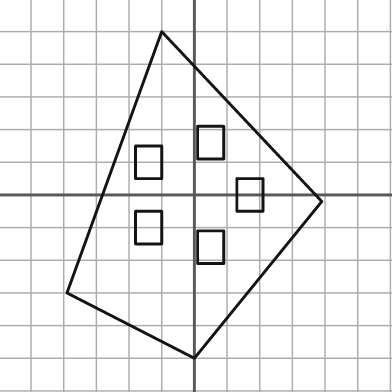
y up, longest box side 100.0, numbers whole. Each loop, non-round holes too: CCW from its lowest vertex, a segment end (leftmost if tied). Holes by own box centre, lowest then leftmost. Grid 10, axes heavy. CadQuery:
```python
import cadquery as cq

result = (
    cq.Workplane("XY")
    .moveTo(0.0, -50.0)
    .lineTo(39.0, -2.0)
    .lineTo(-10.0, 50.0)
    .lineTo(-39.0, -30.0)
    .close()
    .moveTo(1.0, -21.0)
    .lineTo(9.0, -21.0)
    .lineTo(9.0, -11.0)
    .lineTo(1.0, -11.0)
    .close()
    .moveTo(-18.0, -15.0)
    .lineTo(-10.0, -15.0)
    .lineTo(-10.0, -5.0)
    .lineTo(-18.0, -5.0)
    .close()
    .moveTo(13.0, -5.0)
    .lineTo(21.0, -5.0)
    .lineTo(21.0, 5.0)
    .lineTo(13.0, 5.0)
    .close()
    .moveTo(-18.0, 5.0)
    .lineTo(-10.0, 5.0)
    .lineTo(-10.0, 15.0)
    .lineTo(-18.0, 15.0)
    .close()
    .moveTo(1.0, 11.0)
    .lineTo(9.0, 11.0)
    .lineTo(9.0, 21.0)
    .lineTo(1.0, 21.0)
    .close()
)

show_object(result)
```